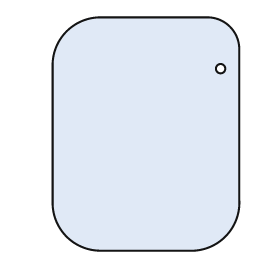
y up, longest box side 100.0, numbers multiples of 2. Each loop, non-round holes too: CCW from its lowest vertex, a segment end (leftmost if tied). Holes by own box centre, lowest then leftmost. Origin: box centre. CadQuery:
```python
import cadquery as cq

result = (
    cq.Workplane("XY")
    .moveTo(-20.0, -50.0)
    .lineTo(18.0, -50.0)
    .threePointArc((34.0, -44.0), (40.0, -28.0))
    .lineTo(40.0, 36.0)
    .threePointArc((36.0, 46.0), (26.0, 50.0))
    .lineTo(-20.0, 50.0)
    .threePointArc((-34.0, 44.0), (-40.0, 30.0))
    .lineTo(-40.0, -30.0)
    .threePointArc((-34.0, -44.0), (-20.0, -50.0))
    .close()
    .moveTo(32.0, 28.0)
    .circle(2.0)
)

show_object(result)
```